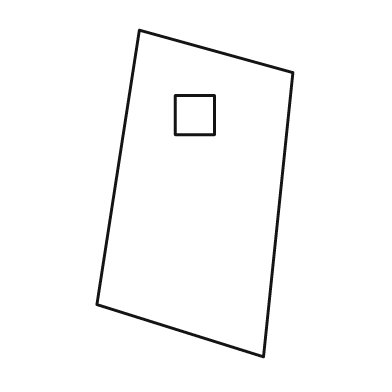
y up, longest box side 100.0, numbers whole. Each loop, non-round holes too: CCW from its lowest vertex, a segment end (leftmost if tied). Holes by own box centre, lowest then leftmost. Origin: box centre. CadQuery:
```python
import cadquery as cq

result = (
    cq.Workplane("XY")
    .moveTo(21.0, -50.0)
    .lineTo(30.0, 37.0)
    .lineTo(-17.0, 50.0)
    .lineTo(-30.0, -34.0)
    .close()
    .moveTo(-6.0, 18.0)
    .lineTo(6.0, 18.0)
    .lineTo(6.0, 30.0)
    .lineTo(-6.0, 30.0)
    .close()
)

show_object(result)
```